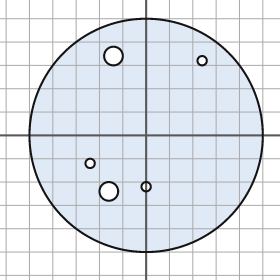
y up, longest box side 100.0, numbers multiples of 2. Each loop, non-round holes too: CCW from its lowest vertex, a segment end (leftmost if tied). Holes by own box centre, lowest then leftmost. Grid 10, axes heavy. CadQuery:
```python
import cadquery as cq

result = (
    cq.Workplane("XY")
    .moveTo(0.0, 0.0)
    .circle(50.0)
    .moveTo(-16.0, -24.0)
    .circle(4.0)
    .moveTo(0.0, -22.0)
    .circle(2.0)
    .moveTo(-24.0, -12.0)
    .circle(2.0)
    .moveTo(24.0, 32.0)
    .circle(2.0)
    .moveTo(-14.0, 34.0)
    .circle(4.0)
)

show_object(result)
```